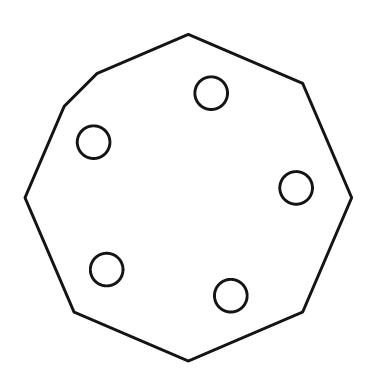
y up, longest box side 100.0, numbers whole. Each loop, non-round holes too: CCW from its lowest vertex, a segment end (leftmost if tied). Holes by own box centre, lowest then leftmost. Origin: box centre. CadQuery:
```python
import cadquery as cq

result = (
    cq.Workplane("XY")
    .moveTo(0.0, -50.0)
    .lineTo(35.0, -35.0)
    .lineTo(50.0, 0.0)
    .lineTo(35.0, 35.0)
    .lineTo(0.0, 50.0)
    .lineTo(-28.0, 38.0)
    .lineTo(-38.0, 28.0)
    .lineTo(-50.0, 0.0)
    .lineTo(-35.0, -35.0)
    .close()
    .moveTo(13.0, -30.0)
    .circle(5.0)
    .moveTo(-25.0, -22.0)
    .circle(5.0)
    .moveTo(33.0, 3.0)
    .circle(5.0)
    .moveTo(-29.0, 17.0)
    .circle(5.0)
    .moveTo(7.0, 32.0)
    .circle(5.0)
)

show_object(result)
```